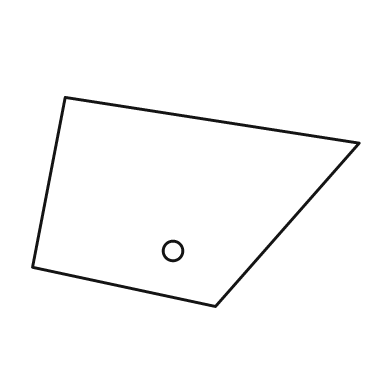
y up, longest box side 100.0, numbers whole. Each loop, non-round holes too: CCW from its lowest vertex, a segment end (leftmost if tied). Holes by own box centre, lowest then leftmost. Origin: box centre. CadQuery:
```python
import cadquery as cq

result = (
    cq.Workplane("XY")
    .moveTo(6.0, -32.0)
    .lineTo(50.0, 18.0)
    .lineTo(-40.0, 32.0)
    .lineTo(-50.0, -20.0)
    .close()
    .moveTo(-7.0, -15.0)
    .circle(3.0)
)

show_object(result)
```